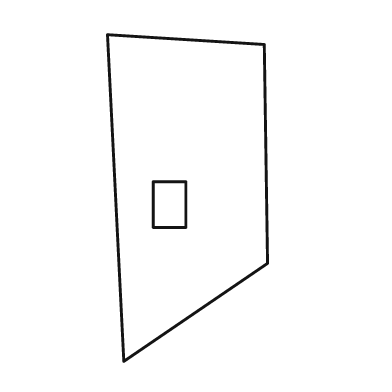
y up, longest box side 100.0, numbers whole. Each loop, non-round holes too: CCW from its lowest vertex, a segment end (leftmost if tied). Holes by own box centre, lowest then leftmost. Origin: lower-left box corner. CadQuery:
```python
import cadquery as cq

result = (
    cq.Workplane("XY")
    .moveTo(5.0, 0.0)
    .lineTo(49.0, 30.0)
    .lineTo(48.0, 97.0)
    .lineTo(0.0, 100.0)
    .close()
    .moveTo(14.0, 41.0)
    .lineTo(24.0, 41.0)
    .lineTo(24.0, 55.0)
    .lineTo(14.0, 55.0)
    .close()
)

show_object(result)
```